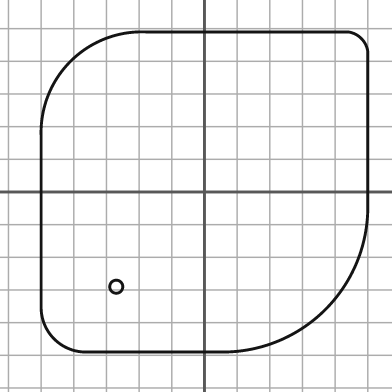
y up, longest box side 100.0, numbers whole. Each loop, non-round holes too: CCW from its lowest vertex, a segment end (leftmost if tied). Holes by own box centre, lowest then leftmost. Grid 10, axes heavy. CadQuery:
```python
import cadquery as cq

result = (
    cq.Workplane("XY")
    .moveTo(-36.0, -49.0)
    .lineTo(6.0, -49.0)
    .threePointArc((37.0, -36.0), (50.0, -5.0))
    .lineTo(50.0, 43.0)
    .threePointArc((48.0, 47.0), (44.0, 49.0))
    .lineTo(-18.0, 49.0)
    .threePointArc((-41.0, 40.0), (-50.0, 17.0))
    .lineTo(-50.0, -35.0)
    .threePointArc((-46.0, -45.0), (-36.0, -49.0))
    .close()
    .moveTo(-27.0, -29.0)
    .circle(2.0)
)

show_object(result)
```